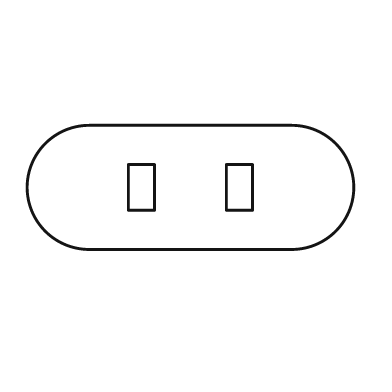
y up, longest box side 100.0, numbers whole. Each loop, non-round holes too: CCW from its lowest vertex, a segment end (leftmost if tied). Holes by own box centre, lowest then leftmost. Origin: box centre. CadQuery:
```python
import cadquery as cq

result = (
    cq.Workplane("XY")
    .moveTo(-31.0, -19.0)
    .lineTo(31.0, -19.0)
    .threePointArc((50.0, 0.0), (31.0, 19.0))
    .lineTo(-31.0, 19.0)
    .threePointArc((-50.0, 0.0), (-31.0, -19.0))
    .close()
    .moveTo(-19.0, -7.0)
    .lineTo(-11.0, -7.0)
    .lineTo(-11.0, 7.0)
    .lineTo(-19.0, 7.0)
    .close()
    .moveTo(11.0, -7.0)
    .lineTo(19.0, -7.0)
    .lineTo(19.0, 7.0)
    .lineTo(11.0, 7.0)
    .close()
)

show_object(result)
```